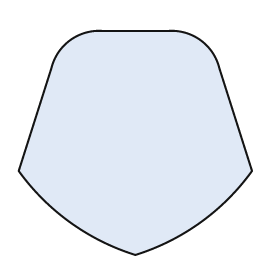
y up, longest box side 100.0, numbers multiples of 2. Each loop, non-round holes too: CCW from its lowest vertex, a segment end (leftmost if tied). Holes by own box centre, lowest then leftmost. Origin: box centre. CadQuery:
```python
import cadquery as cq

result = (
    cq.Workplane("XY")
    .moveTo(0.0, -48.0)
    .threePointArc((28.0, -34.0), (50.0, -12.0))
    .lineTo(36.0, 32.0)
    .threePointArc((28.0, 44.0), (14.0, 48.0))
    .lineTo(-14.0, 48.0)
    .threePointArc((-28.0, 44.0), (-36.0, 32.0))
    .lineTo(-50.0, -12.0)
    .threePointArc((-28.0, -34.0), (0.0, -48.0))
    .close()
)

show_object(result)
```